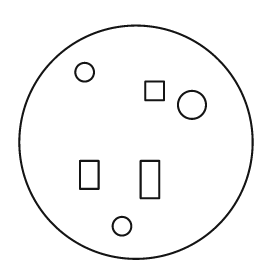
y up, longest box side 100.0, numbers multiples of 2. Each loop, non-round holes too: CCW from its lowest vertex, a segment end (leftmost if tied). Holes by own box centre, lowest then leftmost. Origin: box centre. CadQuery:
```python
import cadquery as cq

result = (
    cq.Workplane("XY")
    .moveTo(0.0, 0.0)
    .circle(50.0)
    .moveTo(-6.0, -36.0)
    .circle(4.0)
    .moveTo(2.0, -24.0)
    .lineTo(10.0, -24.0)
    .lineTo(10.0, -8.0)
    .lineTo(2.0, -8.0)
    .close()
    .moveTo(-24.0, -20.0)
    .lineTo(-16.0, -20.0)
    .lineTo(-16.0, -8.0)
    .lineTo(-24.0, -8.0)
    .close()
    .moveTo(24.0, 16.0)
    .circle(6.0)
    .moveTo(4.0, 18.0)
    .lineTo(12.0, 18.0)
    .lineTo(12.0, 26.0)
    .lineTo(4.0, 26.0)
    .close()
    .moveTo(-22.0, 30.0)
    .circle(4.0)
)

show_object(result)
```